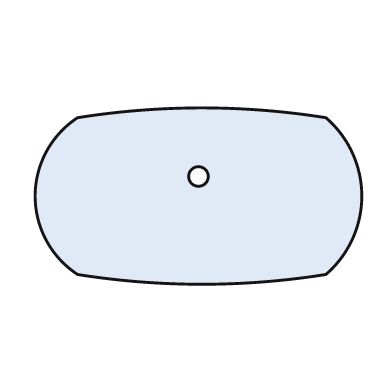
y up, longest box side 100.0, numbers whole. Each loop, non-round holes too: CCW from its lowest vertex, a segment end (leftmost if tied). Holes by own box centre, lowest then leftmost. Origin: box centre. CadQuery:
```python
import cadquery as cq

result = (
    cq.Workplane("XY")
    .moveTo(-37.0, -24.0)
    .threePointArc((1.0, -27.0), (39.0, -24.0))
    .threePointArc((50.0, 0.0), (39.0, 24.0))
    .threePointArc((1.0, 27.0), (-37.0, 24.0))
    .threePointArc((-50.0, 0.0), (-37.0, -24.0))
    .close()
    .moveTo(0.0, 6.0)
    .circle(3.0)
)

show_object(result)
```